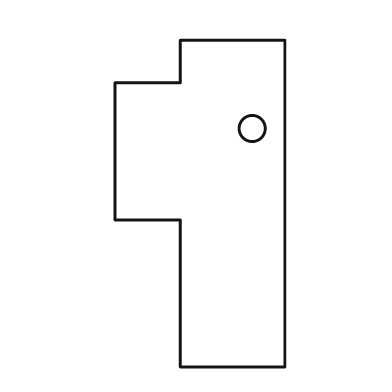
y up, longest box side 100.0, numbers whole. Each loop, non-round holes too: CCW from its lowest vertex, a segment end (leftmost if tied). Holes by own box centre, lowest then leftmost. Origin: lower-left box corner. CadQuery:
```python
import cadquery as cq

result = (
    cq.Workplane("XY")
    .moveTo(20.0, 0.0)
    .lineTo(52.0, 0.0)
    .lineTo(52.0, 100.0)
    .lineTo(20.0, 100.0)
    .lineTo(20.0, 87.0)
    .lineTo(0.0, 87.0)
    .lineTo(0.0, 45.0)
    .lineTo(20.0, 45.0)
    .close()
    .moveTo(42.0, 73.0)
    .circle(4.0)
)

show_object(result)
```